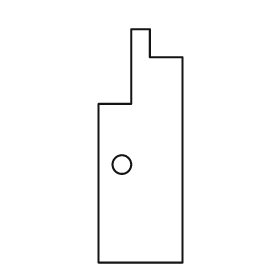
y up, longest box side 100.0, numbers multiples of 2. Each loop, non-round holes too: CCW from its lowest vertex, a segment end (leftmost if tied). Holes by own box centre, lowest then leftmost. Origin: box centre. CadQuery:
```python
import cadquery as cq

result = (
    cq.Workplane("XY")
    .moveTo(-18.0, -50.0)
    .lineTo(18.0, -50.0)
    .lineTo(18.0, 38.0)
    .lineTo(4.0, 38.0)
    .lineTo(4.0, 50.0)
    .lineTo(-4.0, 50.0)
    .lineTo(-4.0, 18.0)
    .lineTo(-18.0, 18.0)
    .close()
    .moveTo(-8.0, -8.0)
    .circle(4.0)
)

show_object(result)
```